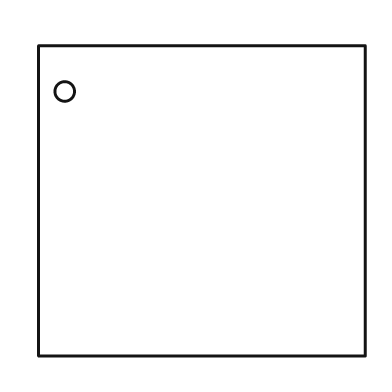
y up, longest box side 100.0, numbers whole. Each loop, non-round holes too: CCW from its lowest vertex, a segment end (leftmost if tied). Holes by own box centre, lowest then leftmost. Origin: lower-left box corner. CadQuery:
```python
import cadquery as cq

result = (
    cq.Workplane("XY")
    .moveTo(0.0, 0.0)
    .lineTo(100.0, 0.0)
    .lineTo(100.0, 95.0)
    .lineTo(0.0, 95.0)
    .close()
    .moveTo(8.0, 81.0)
    .circle(3.0)
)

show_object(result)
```